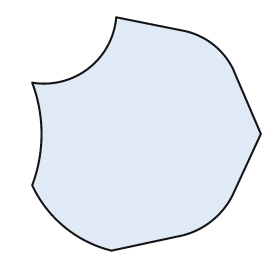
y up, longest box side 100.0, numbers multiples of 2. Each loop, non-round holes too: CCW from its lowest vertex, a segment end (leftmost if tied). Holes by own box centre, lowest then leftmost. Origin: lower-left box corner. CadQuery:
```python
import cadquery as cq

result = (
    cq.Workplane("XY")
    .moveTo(34.0, 0.0)
    .lineTo(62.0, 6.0)
    .threePointArc((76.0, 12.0), (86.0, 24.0))
    .lineTo(98.0, 50.0)
    .lineTo(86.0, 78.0)
    .threePointArc((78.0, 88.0), (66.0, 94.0))
    .lineTo(36.0, 100.0)
    .threePointArc((24.0, 78.0), (0.0, 72.0))
    .threePointArc((4.0, 50.0), (0.0, 28.0))
    .threePointArc((14.0, 10.0), (34.0, 0.0))
    .close()
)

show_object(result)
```